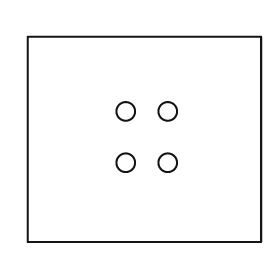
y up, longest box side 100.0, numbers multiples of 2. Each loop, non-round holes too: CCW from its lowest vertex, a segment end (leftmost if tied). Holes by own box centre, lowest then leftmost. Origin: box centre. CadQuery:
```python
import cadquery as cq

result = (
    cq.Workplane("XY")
    .moveTo(-50.0, -44.0)
    .lineTo(50.0, -44.0)
    .lineTo(50.0, 44.0)
    .lineTo(-50.0, 44.0)
    .close()
    .moveTo(-8.0, -10.0)
    .circle(4.0)
    .moveTo(10.0, -10.0)
    .circle(4.0)
    .moveTo(-8.0, 12.0)
    .circle(4.0)
    .moveTo(10.0, 12.0)
    .circle(4.0)
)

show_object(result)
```